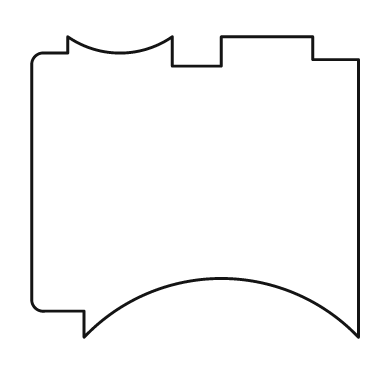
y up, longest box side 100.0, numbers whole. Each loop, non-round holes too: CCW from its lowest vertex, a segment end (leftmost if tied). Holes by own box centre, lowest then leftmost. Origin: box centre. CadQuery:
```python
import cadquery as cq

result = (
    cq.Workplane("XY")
    .moveTo(-34.0, -46.0)
    .threePointArc((8.0, -28.0), (50.0, -46.0))
    .lineTo(50.0, 39.0)
    .lineTo(36.0, 39.0)
    .lineTo(36.0, 46.0)
    .lineTo(8.0, 46.0)
    .lineTo(8.0, 37.0)
    .lineTo(-7.0, 37.0)
    .lineTo(-7.0, 46.0)
    .threePointArc((-23.0, 41.0), (-39.0, 46.0))
    .lineTo(-39.0, 41.0)
    .lineTo(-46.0, 41.0)
    .threePointArc((-49.0, 40.0), (-50.0, 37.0))
    .lineTo(-50.0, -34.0)
    .threePointArc((-49.0, -37.0), (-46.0, -38.0))
    .lineTo(-34.0, -38.0)
    .close()
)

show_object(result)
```